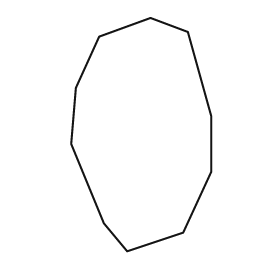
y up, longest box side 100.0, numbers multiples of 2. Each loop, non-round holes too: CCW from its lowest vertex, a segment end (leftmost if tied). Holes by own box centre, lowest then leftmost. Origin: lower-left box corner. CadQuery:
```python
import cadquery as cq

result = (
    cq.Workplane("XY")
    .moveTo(24.0, 0.0)
    .lineTo(48.0, 8.0)
    .lineTo(60.0, 34.0)
    .lineTo(60.0, 58.0)
    .lineTo(50.0, 94.0)
    .lineTo(34.0, 100.0)
    .lineTo(12.0, 92.0)
    .lineTo(2.0, 70.0)
    .lineTo(0.0, 46.0)
    .lineTo(14.0, 12.0)
    .close()
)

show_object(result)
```